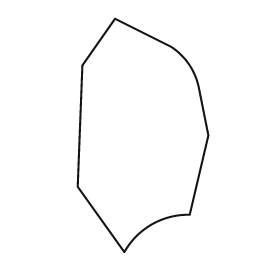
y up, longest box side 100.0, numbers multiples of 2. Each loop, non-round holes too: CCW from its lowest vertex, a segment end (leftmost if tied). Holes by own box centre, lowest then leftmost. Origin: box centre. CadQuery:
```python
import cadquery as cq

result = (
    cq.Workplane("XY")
    .moveTo(-8.0, -50.0)
    .threePointArc((4.0, -38.0), (20.0, -34.0))
    .lineTo(28.0, 0.0)
    .lineTo(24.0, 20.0)
    .threePointArc((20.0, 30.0), (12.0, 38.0))
    .lineTo(-12.0, 50.0)
    .lineTo(-26.0, 30.0)
    .lineTo(-28.0, -22.0)
    .close()
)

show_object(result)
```